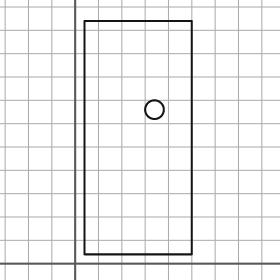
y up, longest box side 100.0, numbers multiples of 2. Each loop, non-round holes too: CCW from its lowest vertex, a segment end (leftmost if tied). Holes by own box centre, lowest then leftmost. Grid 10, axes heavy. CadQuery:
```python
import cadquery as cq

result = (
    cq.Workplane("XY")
    .moveTo(4.0, 4.0)
    .lineTo(50.0, 4.0)
    .lineTo(50.0, 104.0)
    .lineTo(4.0, 104.0)
    .close()
    .moveTo(34.0, 66.0)
    .circle(4.0)
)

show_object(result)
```